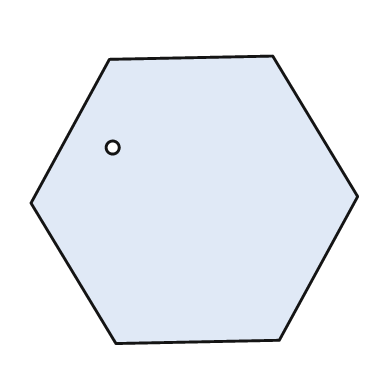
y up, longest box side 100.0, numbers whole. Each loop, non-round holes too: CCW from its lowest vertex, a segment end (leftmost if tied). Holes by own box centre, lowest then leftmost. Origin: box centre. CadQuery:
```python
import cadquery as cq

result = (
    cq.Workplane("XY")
    .moveTo(-24.0, -44.0)
    .lineTo(26.0, -43.0)
    .lineTo(50.0, 1.0)
    .lineTo(24.0, 44.0)
    .lineTo(-26.0, 43.0)
    .lineTo(-50.0, -1.0)
    .close()
    .moveTo(-25.0, 16.0)
    .circle(2.0)
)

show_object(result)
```